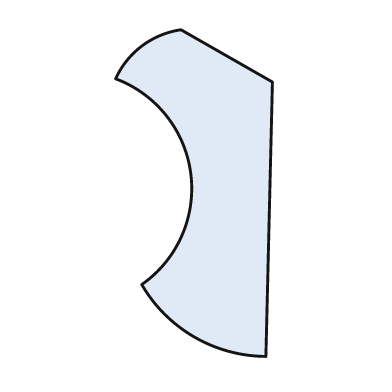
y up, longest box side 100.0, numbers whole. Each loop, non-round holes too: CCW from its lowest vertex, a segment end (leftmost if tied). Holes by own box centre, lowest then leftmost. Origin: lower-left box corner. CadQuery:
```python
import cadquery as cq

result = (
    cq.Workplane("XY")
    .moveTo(46.0, 0.0)
    .lineTo(48.0, 84.0)
    .lineTo(20.0, 100.0)
    .threePointArc((8.0, 95.0), (0.0, 85.0))
    .threePointArc((23.0, 56.0), (8.0, 22.0))
    .threePointArc((24.0, 6.0), (46.0, 0.0))
    .close()
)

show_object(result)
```